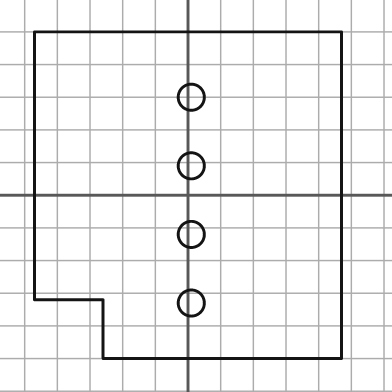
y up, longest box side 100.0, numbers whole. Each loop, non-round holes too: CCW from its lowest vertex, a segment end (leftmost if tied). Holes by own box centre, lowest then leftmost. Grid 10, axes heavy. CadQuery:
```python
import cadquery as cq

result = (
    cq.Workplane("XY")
    .moveTo(-26.0, -50.0)
    .lineTo(47.0, -50.0)
    .lineTo(47.0, 50.0)
    .lineTo(-47.0, 50.0)
    .lineTo(-47.0, -32.0)
    .lineTo(-26.0, -32.0)
    .close()
    .moveTo(1.0, -33.0)
    .circle(4.0)
    .moveTo(1.0, -12.0)
    .circle(4.0)
    .moveTo(1.0, 9.0)
    .circle(4.0)
    .moveTo(1.0, 30.0)
    .circle(4.0)
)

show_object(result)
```